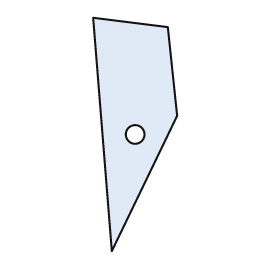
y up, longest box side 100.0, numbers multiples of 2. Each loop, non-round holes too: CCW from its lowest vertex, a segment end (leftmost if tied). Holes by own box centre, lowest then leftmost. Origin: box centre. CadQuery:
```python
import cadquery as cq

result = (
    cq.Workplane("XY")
    .moveTo(-10.0, -50.0)
    .lineTo(18.0, 8.0)
    .lineTo(14.0, 46.0)
    .lineTo(-18.0, 50.0)
    .close()
    .moveTo(0.0, 0.0)
    .circle(4.0)
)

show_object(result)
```